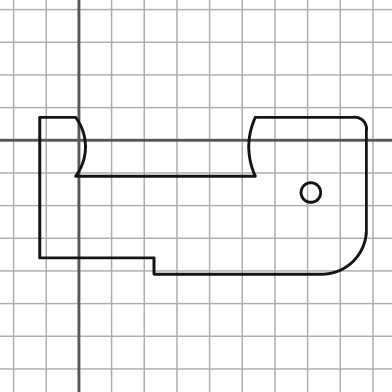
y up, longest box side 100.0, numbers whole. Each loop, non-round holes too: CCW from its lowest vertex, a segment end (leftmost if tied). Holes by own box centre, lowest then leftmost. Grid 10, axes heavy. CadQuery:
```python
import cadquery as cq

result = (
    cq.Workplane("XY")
    .moveTo(23.0, -41.0)
    .lineTo(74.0, -41.0)
    .threePointArc((84.0, -37.0), (88.0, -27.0))
    .lineTo(88.0, 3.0)
    .threePointArc((87.0, 6.0), (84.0, 7.0))
    .lineTo(54.0, 7.0)
    .threePointArc((52.0, -2.0), (54.0, -11.0))
    .lineTo(-1.0, -11.0)
    .threePointArc((2.0, -2.0), (-1.0, 7.0))
    .lineTo(-12.0, 7.0)
    .lineTo(-12.0, -36.0)
    .lineTo(23.0, -36.0)
    .close()
    .moveTo(71.0, -16.0)
    .circle(3.0)
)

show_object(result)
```